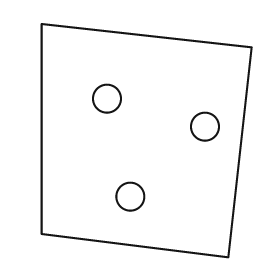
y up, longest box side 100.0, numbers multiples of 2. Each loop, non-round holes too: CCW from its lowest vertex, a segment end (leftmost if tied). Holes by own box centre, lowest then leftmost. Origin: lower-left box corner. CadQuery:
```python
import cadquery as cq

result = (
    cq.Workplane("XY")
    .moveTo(80.0, 0.0)
    .lineTo(90.0, 90.0)
    .lineTo(0.0, 100.0)
    .lineTo(0.0, 10.0)
    .close()
    .moveTo(38.0, 26.0)
    .circle(6.0)
    .moveTo(70.0, 56.0)
    .circle(6.0)
    .moveTo(28.0, 68.0)
    .circle(6.0)
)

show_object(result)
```